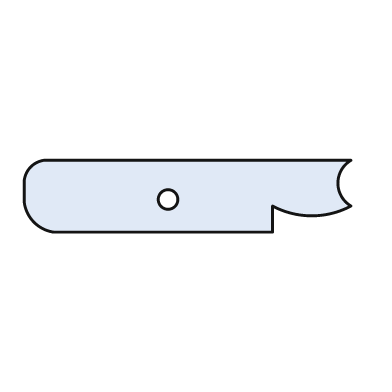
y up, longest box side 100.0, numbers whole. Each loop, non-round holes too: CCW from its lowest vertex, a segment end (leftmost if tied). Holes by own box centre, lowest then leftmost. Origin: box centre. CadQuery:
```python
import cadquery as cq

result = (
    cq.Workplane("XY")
    .moveTo(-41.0, -11.0)
    .lineTo(26.0, -11.0)
    .lineTo(26.0, -3.0)
    .threePointArc((38.0, -6.0), (50.0, -3.0))
    .threePointArc((46.0, 4.0), (50.0, 11.0))
    .lineTo(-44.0, 11.0)
    .threePointArc((-48.0, 9.0), (-50.0, 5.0))
    .lineTo(-50.0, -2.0)
    .threePointArc((-47.0, -8.0), (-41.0, -11.0))
    .close()
    .moveTo(-6.0, -1.0)
    .circle(3.0)
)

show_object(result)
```